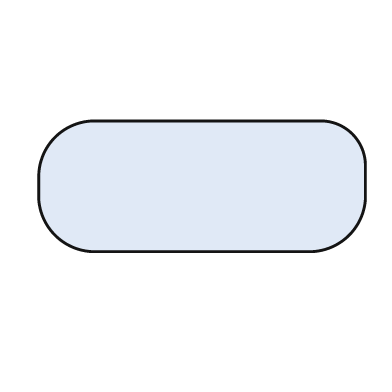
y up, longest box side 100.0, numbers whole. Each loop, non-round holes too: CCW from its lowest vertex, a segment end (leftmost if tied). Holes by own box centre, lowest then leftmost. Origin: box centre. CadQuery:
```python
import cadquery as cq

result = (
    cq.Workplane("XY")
    .moveTo(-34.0, -20.0)
    .lineTo(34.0, -20.0)
    .threePointArc((45.0, -15.0), (50.0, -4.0))
    .lineTo(50.0, 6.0)
    .threePointArc((46.0, 16.0), (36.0, 20.0))
    .lineTo(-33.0, 20.0)
    .threePointArc((-45.0, 15.0), (-50.0, 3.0))
    .lineTo(-50.0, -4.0)
    .threePointArc((-45.0, -15.0), (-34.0, -20.0))
    .close()
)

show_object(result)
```